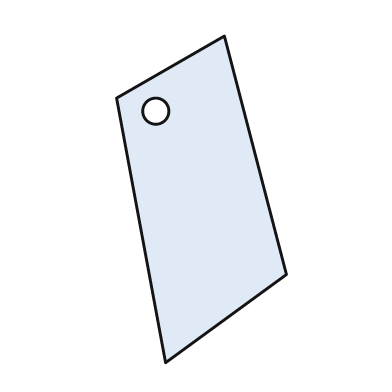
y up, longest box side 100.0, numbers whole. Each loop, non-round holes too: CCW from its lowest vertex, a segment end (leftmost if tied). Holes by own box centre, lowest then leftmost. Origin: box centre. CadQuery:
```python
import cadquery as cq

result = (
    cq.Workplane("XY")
    .moveTo(-11.0, -50.0)
    .lineTo(26.0, -23.0)
    .lineTo(7.0, 50.0)
    .lineTo(-26.0, 31.0)
    .close()
    .moveTo(-14.0, 27.0)
    .circle(4.0)
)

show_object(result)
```